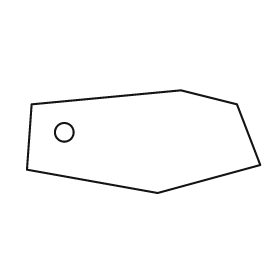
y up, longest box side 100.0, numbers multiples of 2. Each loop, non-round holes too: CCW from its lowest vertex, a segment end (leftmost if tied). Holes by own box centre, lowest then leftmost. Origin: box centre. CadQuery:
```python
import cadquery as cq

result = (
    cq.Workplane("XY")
    .moveTo(6.0, -22.0)
    .lineTo(50.0, -10.0)
    .lineTo(40.0, 16.0)
    .lineTo(16.0, 22.0)
    .lineTo(-48.0, 16.0)
    .lineTo(-50.0, -12.0)
    .close()
    .moveTo(-34.0, 4.0)
    .circle(4.0)
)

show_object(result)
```